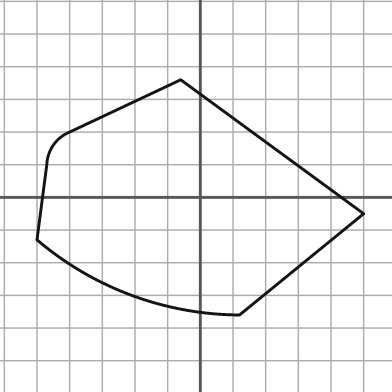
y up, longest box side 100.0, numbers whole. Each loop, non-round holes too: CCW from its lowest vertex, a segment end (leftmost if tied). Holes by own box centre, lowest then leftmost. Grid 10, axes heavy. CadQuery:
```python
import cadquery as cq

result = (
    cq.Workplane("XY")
    .moveTo(12.0, -36.0)
    .lineTo(50.0, -5.0)
    .lineTo(-6.0, 36.0)
    .lineTo(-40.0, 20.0)
    .threePointArc((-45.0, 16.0), (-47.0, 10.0))
    .lineTo(-50.0, -13.0)
    .threePointArc((-21.0, -30.0), (12.0, -36.0))
    .close()
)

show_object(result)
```